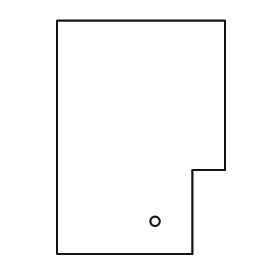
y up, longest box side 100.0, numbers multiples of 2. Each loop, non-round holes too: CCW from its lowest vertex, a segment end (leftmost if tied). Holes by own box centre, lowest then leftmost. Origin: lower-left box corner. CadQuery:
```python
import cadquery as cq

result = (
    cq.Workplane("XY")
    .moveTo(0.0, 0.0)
    .lineTo(58.0, 0.0)
    .lineTo(58.0, 36.0)
    .lineTo(72.0, 36.0)
    .lineTo(72.0, 100.0)
    .lineTo(0.0, 100.0)
    .close()
    .moveTo(42.0, 14.0)
    .circle(2.0)
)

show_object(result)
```